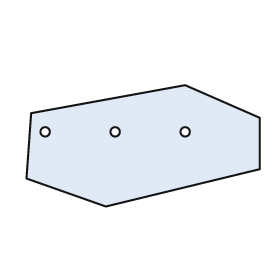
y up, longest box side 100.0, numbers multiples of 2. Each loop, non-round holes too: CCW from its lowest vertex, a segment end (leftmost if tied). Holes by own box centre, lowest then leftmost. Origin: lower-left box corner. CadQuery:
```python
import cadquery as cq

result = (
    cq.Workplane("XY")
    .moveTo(34.0, 0.0)
    .lineTo(100.0, 16.0)
    .lineTo(100.0, 38.0)
    .lineTo(68.0, 52.0)
    .lineTo(2.0, 40.0)
    .lineTo(0.0, 12.0)
    .close()
    .moveTo(8.0, 32.0)
    .circle(2.0)
    .moveTo(38.0, 32.0)
    .circle(2.0)
    .moveTo(68.0, 32.0)
    .circle(2.0)
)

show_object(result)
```